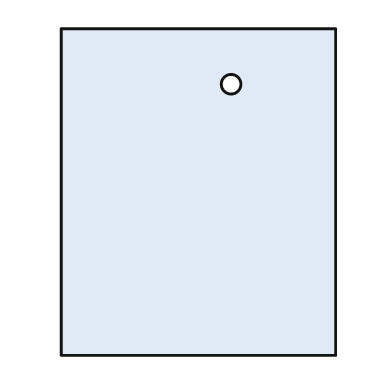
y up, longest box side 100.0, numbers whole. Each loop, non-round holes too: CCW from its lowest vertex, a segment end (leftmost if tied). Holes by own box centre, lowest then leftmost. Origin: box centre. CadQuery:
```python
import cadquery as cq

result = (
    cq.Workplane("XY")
    .moveTo(-42.0, -50.0)
    .lineTo(42.0, -50.0)
    .lineTo(42.0, 50.0)
    .lineTo(-42.0, 50.0)
    .close()
    .moveTo(10.0, 33.0)
    .circle(3.0)
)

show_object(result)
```